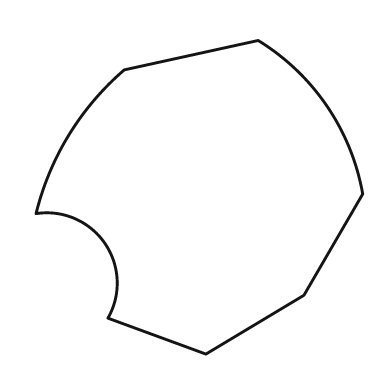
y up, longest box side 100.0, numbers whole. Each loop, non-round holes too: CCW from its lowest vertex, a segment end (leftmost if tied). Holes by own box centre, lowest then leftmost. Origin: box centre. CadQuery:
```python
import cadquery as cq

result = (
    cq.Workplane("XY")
    .moveTo(2.0, -48.0)
    .lineTo(32.0, -30.0)
    .lineTo(50.0, 1.0)
    .threePointArc((39.0, 28.0), (18.0, 48.0))
    .lineTo(-23.0, 39.0)
    .threePointArc((-40.0, 19.0), (-50.0, -5.0))
    .threePointArc((-29.0, -14.0), (-28.0, -37.0))
    .close()
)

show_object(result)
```